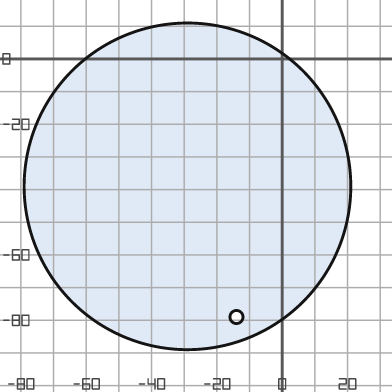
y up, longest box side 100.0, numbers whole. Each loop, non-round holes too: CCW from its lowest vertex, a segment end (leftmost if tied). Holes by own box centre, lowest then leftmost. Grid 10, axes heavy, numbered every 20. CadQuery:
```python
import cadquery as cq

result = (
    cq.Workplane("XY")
    .moveTo(-29.0, -39.0)
    .circle(50.0)
    .moveTo(-14.0, -79.0)
    .circle(2.0)
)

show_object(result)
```